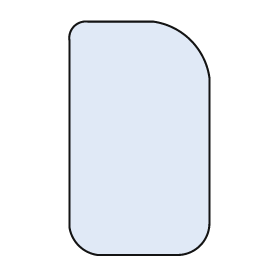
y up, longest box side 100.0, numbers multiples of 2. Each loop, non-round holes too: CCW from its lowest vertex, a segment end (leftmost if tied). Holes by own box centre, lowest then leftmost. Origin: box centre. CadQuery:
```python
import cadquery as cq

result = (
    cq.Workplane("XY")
    .moveTo(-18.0, -50.0)
    .lineTo(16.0, -50.0)
    .threePointArc((26.0, -46.0), (30.0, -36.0))
    .lineTo(30.0, 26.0)
    .threePointArc((22.0, 42.0), (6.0, 50.0))
    .lineTo(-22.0, 50.0)
    .threePointArc((-28.0, 48.0), (-30.0, 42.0))
    .lineTo(-30.0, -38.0)
    .threePointArc((-26.0, -46.0), (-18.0, -50.0))
    .close()
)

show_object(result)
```